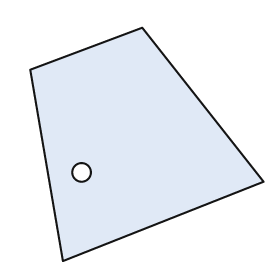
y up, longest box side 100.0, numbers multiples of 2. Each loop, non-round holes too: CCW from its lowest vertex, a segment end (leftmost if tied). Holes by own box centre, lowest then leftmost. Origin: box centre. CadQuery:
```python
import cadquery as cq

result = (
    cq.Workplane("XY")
    .moveTo(-36.0, -50.0)
    .lineTo(50.0, -16.0)
    .lineTo(-2.0, 50.0)
    .lineTo(-50.0, 32.0)
    .close()
    .moveTo(-28.0, -12.0)
    .circle(4.0)
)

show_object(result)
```